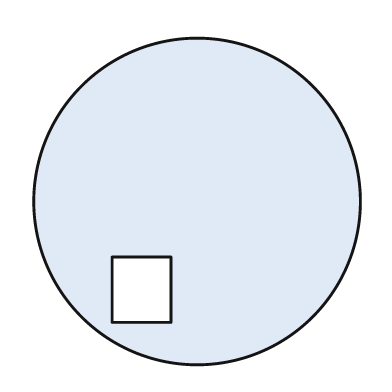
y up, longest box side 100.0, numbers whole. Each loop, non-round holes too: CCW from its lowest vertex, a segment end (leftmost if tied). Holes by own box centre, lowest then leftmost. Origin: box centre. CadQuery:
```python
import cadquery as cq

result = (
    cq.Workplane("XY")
    .moveTo(0.0, 0.0)
    .circle(50.0)
    .moveTo(-26.0, -37.0)
    .lineTo(-8.0, -37.0)
    .lineTo(-8.0, -17.0)
    .lineTo(-26.0, -17.0)
    .close()
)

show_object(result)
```